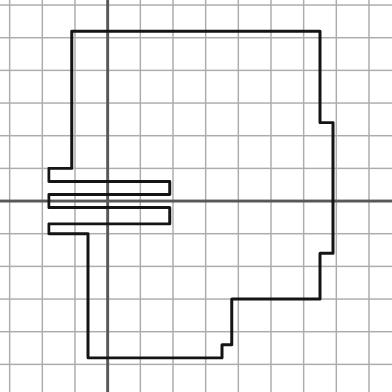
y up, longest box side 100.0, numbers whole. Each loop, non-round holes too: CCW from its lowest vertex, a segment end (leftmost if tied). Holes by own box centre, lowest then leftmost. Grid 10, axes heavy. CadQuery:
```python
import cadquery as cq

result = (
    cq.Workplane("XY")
    .moveTo(-6.0, -48.0)
    .lineTo(35.0, -48.0)
    .lineTo(35.0, -44.0)
    .lineTo(38.0, -44.0)
    .lineTo(38.0, -30.0)
    .lineTo(65.0, -30.0)
    .lineTo(65.0, -16.0)
    .lineTo(69.0, -16.0)
    .lineTo(69.0, 24.0)
    .lineTo(65.0, 24.0)
    .lineTo(65.0, 52.0)
    .lineTo(-11.0, 52.0)
    .lineTo(-11.0, 10.0)
    .lineTo(-18.0, 10.0)
    .lineTo(-18.0, 6.0)
    .lineTo(19.0, 6.0)
    .lineTo(19.0, 2.0)
    .lineTo(-18.0, 2.0)
    .lineTo(-18.0, -2.0)
    .lineTo(19.0, -2.0)
    .lineTo(19.0, -7.0)
    .lineTo(-18.0, -7.0)
    .lineTo(-18.0, -10.0)
    .lineTo(-6.0, -10.0)
    .close()
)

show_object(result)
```